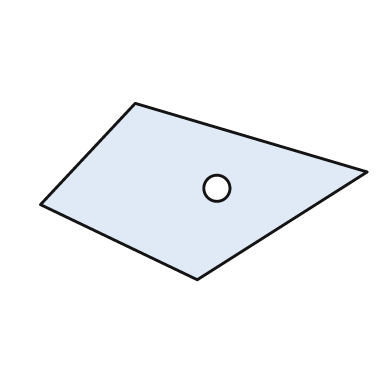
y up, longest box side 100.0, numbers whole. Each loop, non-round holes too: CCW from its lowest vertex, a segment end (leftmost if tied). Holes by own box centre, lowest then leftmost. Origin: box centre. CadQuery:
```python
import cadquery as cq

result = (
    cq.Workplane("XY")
    .moveTo(-2.0, -27.0)
    .lineTo(50.0, 6.0)
    .lineTo(-21.0, 27.0)
    .lineTo(-50.0, -4.0)
    .close()
    .moveTo(4.0, 1.0)
    .circle(4.0)
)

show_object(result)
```